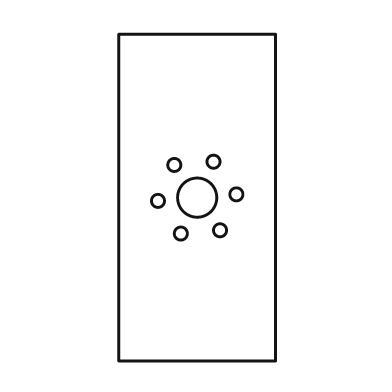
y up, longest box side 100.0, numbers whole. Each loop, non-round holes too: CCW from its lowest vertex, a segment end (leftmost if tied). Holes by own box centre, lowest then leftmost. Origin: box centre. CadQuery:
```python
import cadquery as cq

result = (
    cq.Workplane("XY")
    .moveTo(-24.0, -50.0)
    .lineTo(24.0, -50.0)
    .lineTo(24.0, 50.0)
    .lineTo(-24.0, 50.0)
    .close()
    .moveTo(-5.0, -11.0)
    .circle(2.0)
    .moveTo(7.0, -10.0)
    .circle(2.0)
    .moveTo(-12.0, -1.0)
    .circle(2.0)
    .moveTo(0.0, 0.0)
    .circle(6.0)
    .moveTo(12.0, 1.0)
    .circle(2.0)
    .moveTo(-7.0, 10.0)
    .circle(2.0)
    .moveTo(5.0, 11.0)
    .circle(2.0)
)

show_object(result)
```